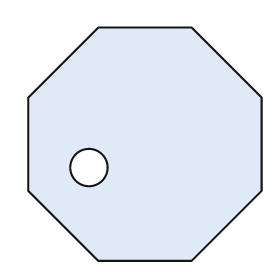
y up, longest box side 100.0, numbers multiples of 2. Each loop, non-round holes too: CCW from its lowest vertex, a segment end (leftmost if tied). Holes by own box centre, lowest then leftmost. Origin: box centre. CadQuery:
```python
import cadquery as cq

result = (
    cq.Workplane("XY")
    .moveTo(-20.0, -50.0)
    .lineTo(20.0, -50.0)
    .lineTo(50.0, -20.0)
    .lineTo(50.0, 20.0)
    .lineTo(20.0, 50.0)
    .lineTo(-20.0, 50.0)
    .lineTo(-50.0, 20.0)
    .lineTo(-50.0, -20.0)
    .close()
    .moveTo(-24.0, -10.0)
    .circle(8.0)
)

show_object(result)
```